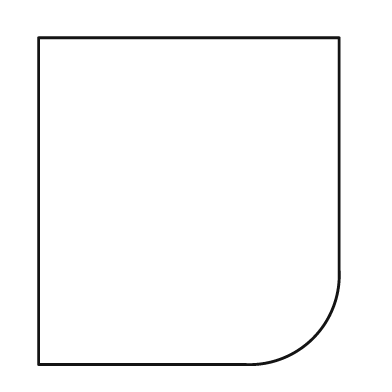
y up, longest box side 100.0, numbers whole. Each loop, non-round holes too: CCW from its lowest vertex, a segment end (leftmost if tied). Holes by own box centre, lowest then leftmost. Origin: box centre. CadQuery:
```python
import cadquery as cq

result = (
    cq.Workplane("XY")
    .moveTo(-46.0, -50.0)
    .lineTo(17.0, -50.0)
    .threePointArc((38.0, -42.0), (46.0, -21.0))
    .lineTo(46.0, 50.0)
    .lineTo(-46.0, 50.0)
    .close()
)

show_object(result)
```